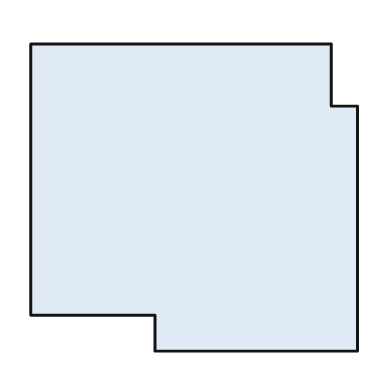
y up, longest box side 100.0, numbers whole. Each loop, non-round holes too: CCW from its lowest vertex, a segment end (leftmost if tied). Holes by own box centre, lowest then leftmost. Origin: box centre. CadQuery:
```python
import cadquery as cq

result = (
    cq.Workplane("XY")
    .moveTo(-12.0, -47.0)
    .lineTo(50.0, -47.0)
    .lineTo(50.0, 28.0)
    .lineTo(42.0, 28.0)
    .lineTo(42.0, 47.0)
    .lineTo(-50.0, 47.0)
    .lineTo(-50.0, -36.0)
    .lineTo(-12.0, -36.0)
    .close()
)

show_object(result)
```